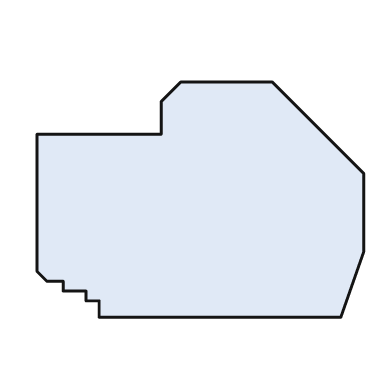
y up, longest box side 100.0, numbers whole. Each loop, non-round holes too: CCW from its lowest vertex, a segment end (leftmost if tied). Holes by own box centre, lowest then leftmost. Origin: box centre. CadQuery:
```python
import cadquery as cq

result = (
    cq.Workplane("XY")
    .moveTo(-31.0, -36.0)
    .lineTo(43.0, -36.0)
    .lineTo(50.0, -16.0)
    .lineTo(50.0, 8.0)
    .lineTo(22.0, 36.0)
    .lineTo(-6.0, 36.0)
    .lineTo(-12.0, 30.0)
    .lineTo(-12.0, 20.0)
    .lineTo(-50.0, 20.0)
    .lineTo(-50.0, -22.0)
    .lineTo(-47.0, -25.0)
    .lineTo(-42.0, -25.0)
    .lineTo(-42.0, -28.0)
    .lineTo(-35.0, -28.0)
    .lineTo(-35.0, -31.0)
    .lineTo(-31.0, -31.0)
    .close()
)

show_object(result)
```